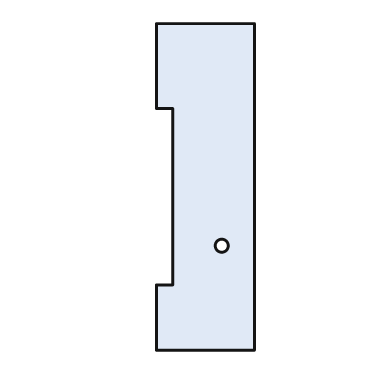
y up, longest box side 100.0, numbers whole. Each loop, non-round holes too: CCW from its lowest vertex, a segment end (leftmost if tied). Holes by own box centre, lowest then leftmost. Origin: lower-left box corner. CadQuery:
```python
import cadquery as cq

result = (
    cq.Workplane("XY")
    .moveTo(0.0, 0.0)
    .lineTo(30.0, 0.0)
    .lineTo(30.0, 100.0)
    .lineTo(0.0, 100.0)
    .lineTo(0.0, 74.0)
    .lineTo(5.0, 74.0)
    .lineTo(5.0, 20.0)
    .lineTo(0.0, 20.0)
    .close()
    .moveTo(20.0, 32.0)
    .circle(2.0)
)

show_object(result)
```